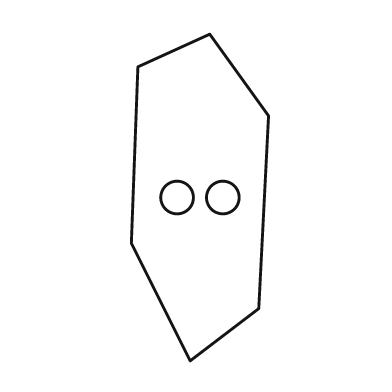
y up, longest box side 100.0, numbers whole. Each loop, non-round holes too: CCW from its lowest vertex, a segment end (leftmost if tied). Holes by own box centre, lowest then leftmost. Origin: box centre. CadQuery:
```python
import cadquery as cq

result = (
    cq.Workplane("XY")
    .moveTo(-3.0, -50.0)
    .lineTo(18.0, -34.0)
    .lineTo(21.0, 25.0)
    .lineTo(3.0, 50.0)
    .lineTo(-19.0, 40.0)
    .lineTo(-21.0, -14.0)
    .close()
    .moveTo(-7.0, 0.0)
    .circle(5.0)
    .moveTo(7.0, 0.0)
    .circle(5.0)
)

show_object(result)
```